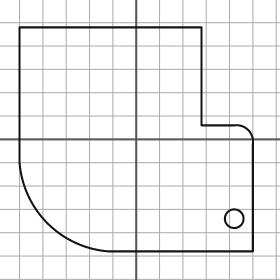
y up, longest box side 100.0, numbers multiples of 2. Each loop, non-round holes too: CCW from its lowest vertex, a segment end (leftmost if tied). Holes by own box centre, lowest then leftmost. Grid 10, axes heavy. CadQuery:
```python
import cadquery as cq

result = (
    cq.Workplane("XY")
    .moveTo(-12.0, -48.0)
    .lineTo(50.0, -48.0)
    .lineTo(50.0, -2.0)
    .threePointArc((48.0, 4.0), (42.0, 6.0))
    .lineTo(28.0, 6.0)
    .lineTo(28.0, 48.0)
    .lineTo(-50.0, 48.0)
    .lineTo(-50.0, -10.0)
    .threePointArc((-38.0, -36.0), (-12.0, -48.0))
    .close()
    .moveTo(42.0, -34.0)
    .circle(4.0)
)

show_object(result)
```